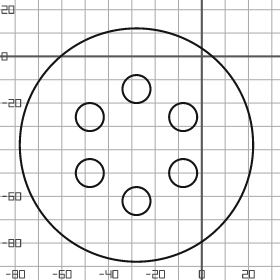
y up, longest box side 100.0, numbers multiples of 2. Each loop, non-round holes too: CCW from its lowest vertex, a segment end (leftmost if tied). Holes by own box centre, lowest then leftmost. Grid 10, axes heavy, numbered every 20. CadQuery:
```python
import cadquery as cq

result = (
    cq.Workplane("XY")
    .moveTo(-28.0, -38.0)
    .circle(50.0)
    .moveTo(-28.0, -62.0)
    .circle(6.0)
    .moveTo(-48.0, -50.0)
    .circle(6.0)
    .moveTo(-8.0, -50.0)
    .circle(6.0)
    .moveTo(-48.0, -26.0)
    .circle(6.0)
    .moveTo(-8.0, -26.0)
    .circle(6.0)
    .moveTo(-28.0, -14.0)
    .circle(6.0)
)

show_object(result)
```